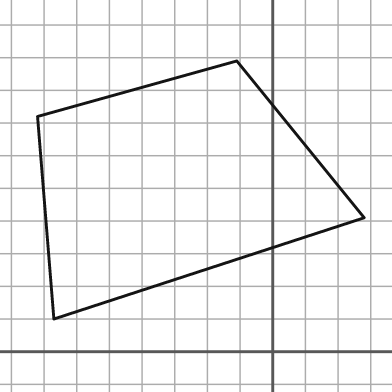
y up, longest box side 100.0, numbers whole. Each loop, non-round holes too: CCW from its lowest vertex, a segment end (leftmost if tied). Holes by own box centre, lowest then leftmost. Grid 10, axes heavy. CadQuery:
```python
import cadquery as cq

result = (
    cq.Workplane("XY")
    .moveTo(-67.0, 10.0)
    .lineTo(28.0, 41.0)
    .lineTo(-11.0, 89.0)
    .lineTo(-72.0, 72.0)
    .close()
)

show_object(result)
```